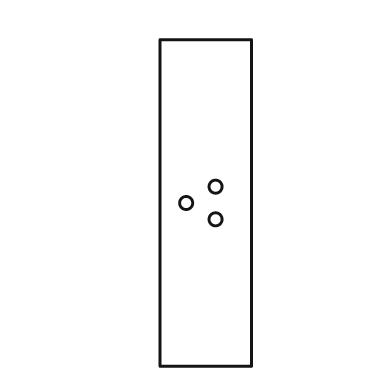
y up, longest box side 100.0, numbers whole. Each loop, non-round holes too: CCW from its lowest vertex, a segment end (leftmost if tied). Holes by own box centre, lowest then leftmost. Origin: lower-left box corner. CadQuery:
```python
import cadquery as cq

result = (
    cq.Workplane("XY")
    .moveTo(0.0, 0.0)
    .lineTo(28.0, 0.0)
    .lineTo(28.0, 100.0)
    .lineTo(0.0, 100.0)
    .close()
    .moveTo(17.0, 45.0)
    .circle(2.0)
    .moveTo(8.0, 50.0)
    .circle(2.0)
    .moveTo(17.0, 55.0)
    .circle(2.0)
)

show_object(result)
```